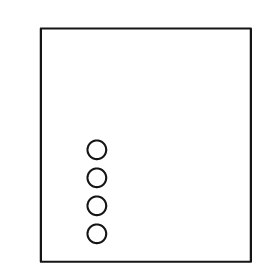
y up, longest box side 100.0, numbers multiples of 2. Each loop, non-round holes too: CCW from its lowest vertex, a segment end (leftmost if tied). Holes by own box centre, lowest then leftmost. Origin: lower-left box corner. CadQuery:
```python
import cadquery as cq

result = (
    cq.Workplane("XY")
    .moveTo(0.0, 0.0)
    .lineTo(90.0, 0.0)
    .lineTo(90.0, 100.0)
    .lineTo(0.0, 100.0)
    .close()
    .moveTo(24.0, 12.0)
    .circle(4.0)
    .moveTo(24.0, 24.0)
    .circle(4.0)
    .moveTo(24.0, 36.0)
    .circle(4.0)
    .moveTo(24.0, 48.0)
    .circle(4.0)
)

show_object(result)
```